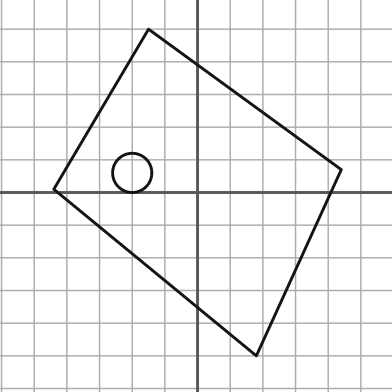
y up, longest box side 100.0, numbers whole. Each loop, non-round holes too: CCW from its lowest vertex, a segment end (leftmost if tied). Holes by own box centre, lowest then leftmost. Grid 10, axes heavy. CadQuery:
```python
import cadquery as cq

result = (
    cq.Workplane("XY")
    .moveTo(18.0, -50.0)
    .lineTo(44.0, 7.0)
    .lineTo(-15.0, 50.0)
    .lineTo(-44.0, 1.0)
    .close()
    .moveTo(-20.0, 6.0)
    .circle(6.0)
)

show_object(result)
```